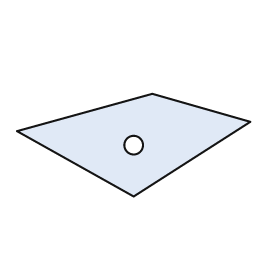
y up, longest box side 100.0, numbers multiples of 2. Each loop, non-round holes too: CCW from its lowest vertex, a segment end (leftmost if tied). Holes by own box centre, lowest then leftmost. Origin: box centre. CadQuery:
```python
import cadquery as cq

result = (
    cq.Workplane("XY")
    .moveTo(0.0, -22.0)
    .lineTo(50.0, 10.0)
    .lineTo(8.0, 22.0)
    .lineTo(-50.0, 6.0)
    .close()
    .moveTo(0.0, 0.0)
    .circle(4.0)
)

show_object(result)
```